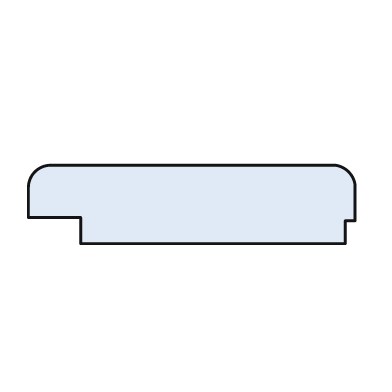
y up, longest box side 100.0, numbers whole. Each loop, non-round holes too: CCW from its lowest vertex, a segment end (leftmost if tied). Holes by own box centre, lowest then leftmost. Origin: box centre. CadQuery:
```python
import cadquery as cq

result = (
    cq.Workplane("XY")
    .moveTo(-34.0, -12.0)
    .lineTo(47.0, -12.0)
    .lineTo(47.0, -5.0)
    .lineTo(50.0, -5.0)
    .lineTo(50.0, 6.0)
    .threePointArc((48.0, 10.0), (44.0, 12.0))
    .lineTo(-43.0, 12.0)
    .threePointArc((-48.0, 10.0), (-50.0, 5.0))
    .lineTo(-50.0, -4.0)
    .lineTo(-34.0, -4.0)
    .close()
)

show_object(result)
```